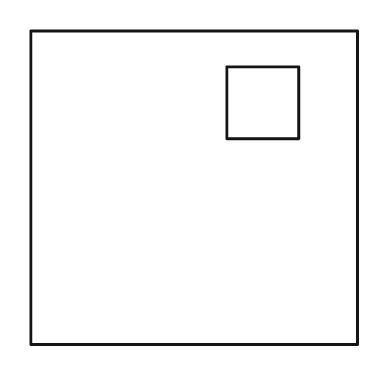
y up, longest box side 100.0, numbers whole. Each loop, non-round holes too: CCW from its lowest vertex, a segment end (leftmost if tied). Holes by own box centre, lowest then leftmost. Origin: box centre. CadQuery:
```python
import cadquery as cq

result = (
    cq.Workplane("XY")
    .moveTo(-50.0, -48.0)
    .lineTo(50.0, -48.0)
    .lineTo(50.0, 48.0)
    .lineTo(-50.0, 48.0)
    .close()
    .moveTo(10.0, 15.0)
    .lineTo(32.0, 15.0)
    .lineTo(32.0, 37.0)
    .lineTo(10.0, 37.0)
    .close()
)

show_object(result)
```